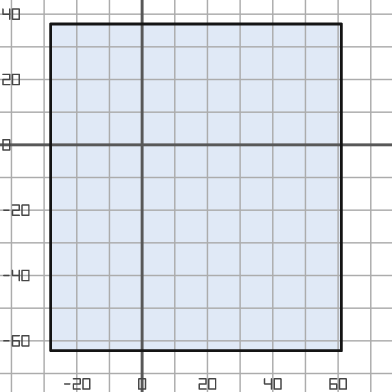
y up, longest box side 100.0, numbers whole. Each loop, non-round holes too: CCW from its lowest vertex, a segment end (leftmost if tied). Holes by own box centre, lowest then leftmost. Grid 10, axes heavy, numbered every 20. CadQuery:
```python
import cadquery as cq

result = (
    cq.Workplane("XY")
    .moveTo(-28.0, -63.0)
    .lineTo(61.0, -63.0)
    .lineTo(61.0, 37.0)
    .lineTo(-28.0, 37.0)
    .close()
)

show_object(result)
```